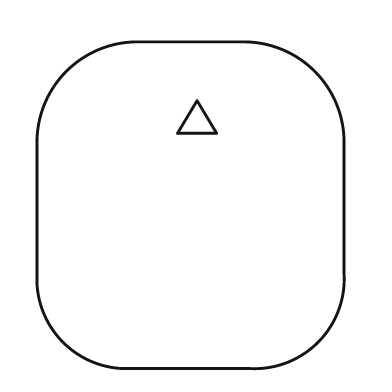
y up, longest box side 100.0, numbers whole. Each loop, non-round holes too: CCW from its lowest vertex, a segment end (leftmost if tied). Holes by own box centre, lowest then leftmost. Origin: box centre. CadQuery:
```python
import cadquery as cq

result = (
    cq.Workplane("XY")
    .moveTo(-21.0, -50.0)
    .lineTo(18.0, -50.0)
    .threePointArc((39.0, -42.0), (47.0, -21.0))
    .lineTo(47.0, 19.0)
    .threePointArc((38.0, 41.0), (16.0, 50.0))
    .lineTo(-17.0, 50.0)
    .threePointArc((-38.0, 41.0), (-47.0, 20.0))
    .lineTo(-47.0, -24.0)
    .threePointArc((-39.0, -42.0), (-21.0, -50.0))
    .close()
    .moveTo(-4.0, 22.0)
    .lineTo(8.0, 22.0)
    .lineTo(2.0, 32.0)
    .close()
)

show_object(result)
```